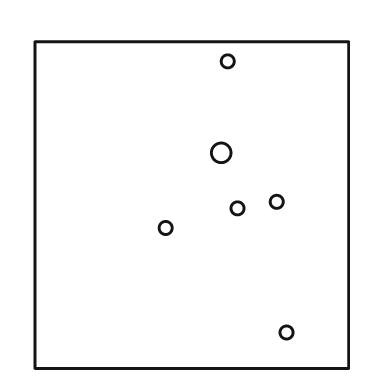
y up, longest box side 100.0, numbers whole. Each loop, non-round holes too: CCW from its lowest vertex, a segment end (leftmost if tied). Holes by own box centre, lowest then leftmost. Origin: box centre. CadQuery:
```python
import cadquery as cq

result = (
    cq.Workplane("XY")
    .moveTo(-48.0, -50.0)
    .lineTo(48.0, -50.0)
    .lineTo(48.0, 50.0)
    .lineTo(-48.0, 50.0)
    .close()
    .moveTo(29.0, -39.0)
    .circle(2.0)
    .moveTo(-8.0, -7.0)
    .circle(2.0)
    .moveTo(14.0, -1.0)
    .circle(2.0)
    .moveTo(26.0, 1.0)
    .circle(2.0)
    .moveTo(9.0, 16.0)
    .circle(3.0)
    .moveTo(11.0, 44.0)
    .circle(2.0)
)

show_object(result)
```